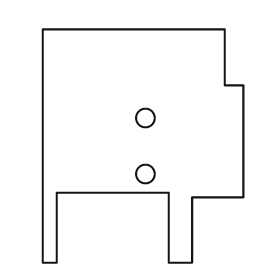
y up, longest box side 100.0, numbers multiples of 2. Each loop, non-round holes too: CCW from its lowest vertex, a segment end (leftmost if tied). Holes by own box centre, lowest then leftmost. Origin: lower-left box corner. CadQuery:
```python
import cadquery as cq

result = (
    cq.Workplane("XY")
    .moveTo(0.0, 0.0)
    .lineTo(6.0, 0.0)
    .lineTo(6.0, 30.0)
    .lineTo(54.0, 30.0)
    .lineTo(54.0, 0.0)
    .lineTo(64.0, 0.0)
    .lineTo(64.0, 28.0)
    .lineTo(86.0, 28.0)
    .lineTo(86.0, 76.0)
    .lineTo(78.0, 76.0)
    .lineTo(78.0, 100.0)
    .lineTo(0.0, 100.0)
    .close()
    .moveTo(44.0, 38.0)
    .circle(4.0)
    .moveTo(44.0, 62.0)
    .circle(4.0)
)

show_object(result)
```